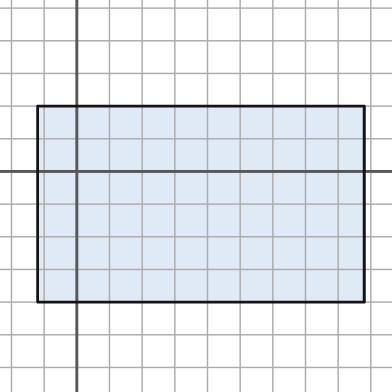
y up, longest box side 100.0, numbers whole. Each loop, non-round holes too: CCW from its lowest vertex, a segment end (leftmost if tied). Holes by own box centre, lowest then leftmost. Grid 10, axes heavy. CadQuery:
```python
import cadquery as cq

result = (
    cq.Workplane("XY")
    .moveTo(-12.0, -40.0)
    .lineTo(88.0, -40.0)
    .lineTo(88.0, 20.0)
    .lineTo(-12.0, 20.0)
    .close()
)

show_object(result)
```